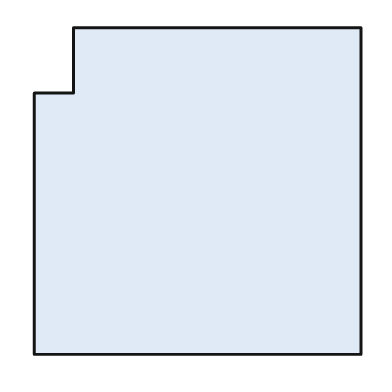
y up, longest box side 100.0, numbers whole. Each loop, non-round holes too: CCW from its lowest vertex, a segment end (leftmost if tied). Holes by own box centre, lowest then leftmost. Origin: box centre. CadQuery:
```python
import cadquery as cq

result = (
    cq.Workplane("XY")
    .moveTo(-50.0, -50.0)
    .lineTo(50.0, -50.0)
    .lineTo(50.0, 50.0)
    .lineTo(-38.0, 50.0)
    .lineTo(-38.0, 30.0)
    .lineTo(-50.0, 30.0)
    .close()
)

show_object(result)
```